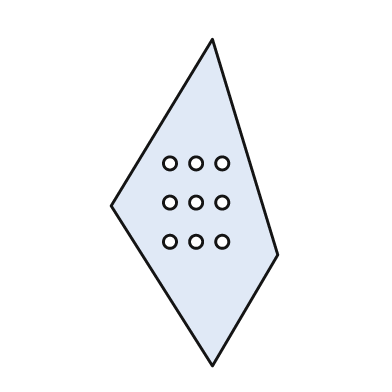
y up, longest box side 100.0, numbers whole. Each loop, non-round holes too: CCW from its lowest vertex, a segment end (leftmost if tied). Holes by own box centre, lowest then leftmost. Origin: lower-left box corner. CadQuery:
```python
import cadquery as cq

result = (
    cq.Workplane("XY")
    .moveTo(31.0, 0.0)
    .lineTo(51.0, 34.0)
    .lineTo(31.0, 100.0)
    .lineTo(0.0, 49.0)
    .close()
    .moveTo(18.0, 38.0)
    .circle(2.0)
    .moveTo(26.0, 38.0)
    .circle(2.0)
    .moveTo(34.0, 38.0)
    .circle(2.0)
    .moveTo(18.0, 50.0)
    .circle(2.0)
    .moveTo(26.0, 50.0)
    .circle(2.0)
    .moveTo(34.0, 50.0)
    .circle(2.0)
    .moveTo(18.0, 62.0)
    .circle(2.0)
    .moveTo(26.0, 62.0)
    .circle(2.0)
    .moveTo(34.0, 62.0)
    .circle(2.0)
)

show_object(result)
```